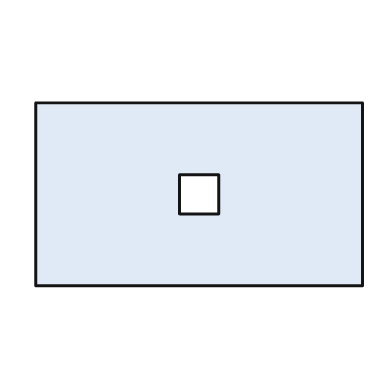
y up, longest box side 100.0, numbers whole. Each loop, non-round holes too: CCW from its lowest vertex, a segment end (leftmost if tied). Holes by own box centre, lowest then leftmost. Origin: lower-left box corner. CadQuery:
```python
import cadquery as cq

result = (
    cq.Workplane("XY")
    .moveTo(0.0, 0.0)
    .lineTo(100.0, 0.0)
    .lineTo(100.0, 56.0)
    .lineTo(0.0, 56.0)
    .close()
    .moveTo(44.0, 22.0)
    .lineTo(56.0, 22.0)
    .lineTo(56.0, 34.0)
    .lineTo(44.0, 34.0)
    .close()
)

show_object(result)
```